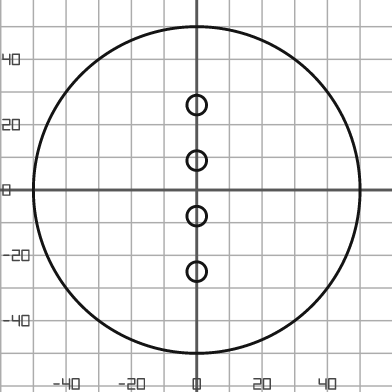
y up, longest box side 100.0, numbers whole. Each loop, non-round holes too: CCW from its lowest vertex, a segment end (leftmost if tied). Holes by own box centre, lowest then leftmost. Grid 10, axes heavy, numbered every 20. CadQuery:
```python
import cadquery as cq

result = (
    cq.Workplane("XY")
    .moveTo(0.0, 0.0)
    .circle(50.0)
    .moveTo(0.0, -25.0)
    .circle(3.0)
    .moveTo(0.0, -8.0)
    .circle(3.0)
    .moveTo(0.0, 9.0)
    .circle(3.0)
    .moveTo(0.0, 26.0)
    .circle(3.0)
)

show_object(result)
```